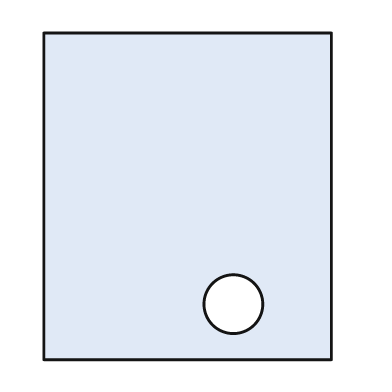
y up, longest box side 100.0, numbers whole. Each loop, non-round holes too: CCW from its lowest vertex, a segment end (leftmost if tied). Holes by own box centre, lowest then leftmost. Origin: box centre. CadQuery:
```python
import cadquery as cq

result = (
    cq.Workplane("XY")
    .moveTo(-44.0, -50.0)
    .lineTo(44.0, -50.0)
    .lineTo(44.0, 50.0)
    .lineTo(-44.0, 50.0)
    .close()
    .moveTo(14.0, -33.0)
    .circle(9.0)
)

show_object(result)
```